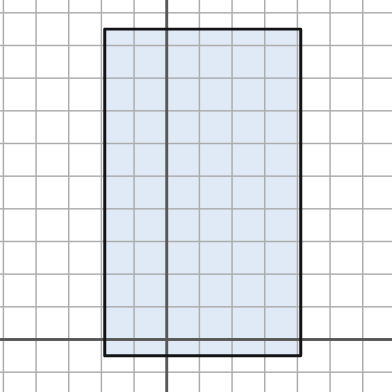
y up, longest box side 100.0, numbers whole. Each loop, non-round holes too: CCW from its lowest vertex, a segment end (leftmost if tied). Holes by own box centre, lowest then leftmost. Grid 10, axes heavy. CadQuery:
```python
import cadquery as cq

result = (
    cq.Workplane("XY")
    .moveTo(-19.0, -5.0)
    .lineTo(41.0, -5.0)
    .lineTo(41.0, 95.0)
    .lineTo(-19.0, 95.0)
    .close()
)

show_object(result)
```